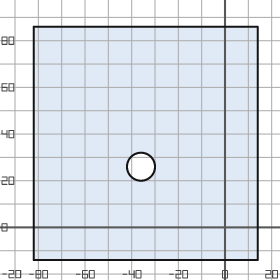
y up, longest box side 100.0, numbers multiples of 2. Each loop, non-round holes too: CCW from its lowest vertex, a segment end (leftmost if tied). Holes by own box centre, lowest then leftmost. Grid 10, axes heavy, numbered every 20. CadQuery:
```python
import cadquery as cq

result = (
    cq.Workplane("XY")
    .moveTo(-82.0, -14.0)
    .lineTo(14.0, -14.0)
    .lineTo(14.0, 86.0)
    .lineTo(-82.0, 86.0)
    .close()
    .moveTo(-36.0, 26.0)
    .circle(6.0)
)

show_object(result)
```